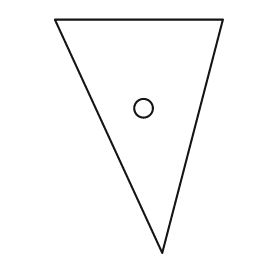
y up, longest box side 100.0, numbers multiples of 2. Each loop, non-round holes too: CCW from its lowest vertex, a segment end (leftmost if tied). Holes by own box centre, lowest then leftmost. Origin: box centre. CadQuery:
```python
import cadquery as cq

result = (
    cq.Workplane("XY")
    .moveTo(10.0, -50.0)
    .lineTo(36.0, 50.0)
    .lineTo(-36.0, 50.0)
    .close()
    .moveTo(2.0, 12.0)
    .circle(4.0)
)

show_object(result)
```